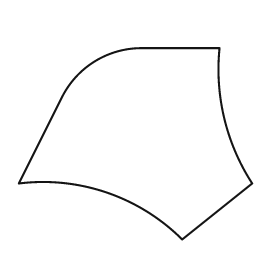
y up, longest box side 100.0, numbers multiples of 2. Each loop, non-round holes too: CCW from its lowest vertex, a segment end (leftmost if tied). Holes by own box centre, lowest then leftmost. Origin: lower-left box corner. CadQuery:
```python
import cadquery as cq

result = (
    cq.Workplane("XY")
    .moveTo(70.0, 0.0)
    .lineTo(100.0, 24.0)
    .threePointArc((88.0, 52.0), (86.0, 82.0))
    .lineTo(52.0, 82.0)
    .threePointArc((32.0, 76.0), (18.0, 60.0))
    .lineTo(0.0, 24.0)
    .threePointArc((38.0, 20.0), (70.0, 0.0))
    .close()
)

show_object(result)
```